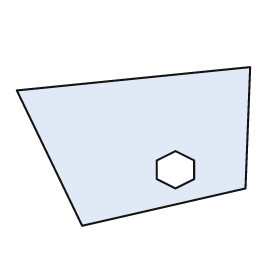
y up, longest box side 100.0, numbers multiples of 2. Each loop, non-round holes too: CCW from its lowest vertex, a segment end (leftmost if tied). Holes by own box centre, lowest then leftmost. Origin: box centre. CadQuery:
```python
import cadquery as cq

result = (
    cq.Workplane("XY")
    .moveTo(-22.0, -34.0)
    .lineTo(48.0, -18.0)
    .lineTo(50.0, 34.0)
    .lineTo(-50.0, 24.0)
    .close()
    .moveTo(18.0, -18.0)
    .lineTo(26.0, -14.0)
    .lineTo(26.0, -6.0)
    .lineTo(18.0, -2.0)
    .lineTo(10.0, -6.0)
    .lineTo(10.0, -14.0)
    .close()
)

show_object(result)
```